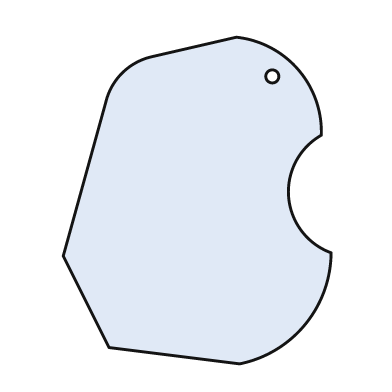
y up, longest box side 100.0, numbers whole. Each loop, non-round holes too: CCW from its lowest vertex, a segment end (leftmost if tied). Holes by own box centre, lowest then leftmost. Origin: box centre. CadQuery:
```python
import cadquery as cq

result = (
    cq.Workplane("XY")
    .moveTo(13.0, -50.0)
    .threePointArc((33.0, -38.0), (41.0, -16.0))
    .threePointArc((28.0, 1.0), (38.0, 20.0))
    .threePointArc((31.0, 40.0), (12.0, 50.0))
    .lineTo(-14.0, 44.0)
    .threePointArc((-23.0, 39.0), (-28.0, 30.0))
    .lineTo(-41.0, -17.0)
    .lineTo(-27.0, -45.0)
    .close()
    .moveTo(23.0, 38.0)
    .circle(2.0)
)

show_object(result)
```